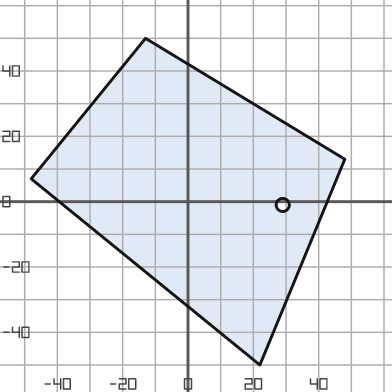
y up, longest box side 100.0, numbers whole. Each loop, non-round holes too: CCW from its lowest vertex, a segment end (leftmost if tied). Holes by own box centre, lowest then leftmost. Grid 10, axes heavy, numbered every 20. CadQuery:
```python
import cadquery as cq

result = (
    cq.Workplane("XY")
    .moveTo(22.0, -50.0)
    .lineTo(48.0, 13.0)
    .lineTo(-13.0, 50.0)
    .lineTo(-48.0, 7.0)
    .close()
    .moveTo(29.0, -1.0)
    .circle(2.0)
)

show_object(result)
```